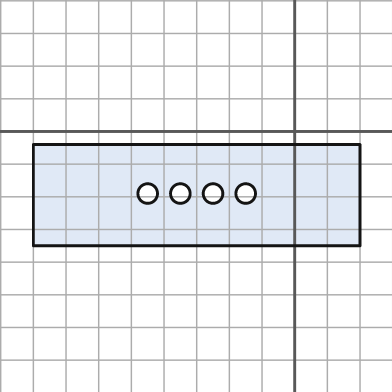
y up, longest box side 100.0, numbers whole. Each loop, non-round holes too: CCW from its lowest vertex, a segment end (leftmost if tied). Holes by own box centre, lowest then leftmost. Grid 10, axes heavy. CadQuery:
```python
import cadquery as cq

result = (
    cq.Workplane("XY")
    .moveTo(-80.0, -35.0)
    .lineTo(20.0, -35.0)
    .lineTo(20.0, -4.0)
    .lineTo(-80.0, -4.0)
    .close()
    .moveTo(-45.0, -19.0)
    .circle(3.0)
    .moveTo(-35.0, -19.0)
    .circle(3.0)
    .moveTo(-25.0, -19.0)
    .circle(3.0)
    .moveTo(-15.0, -19.0)
    .circle(3.0)
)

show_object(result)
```